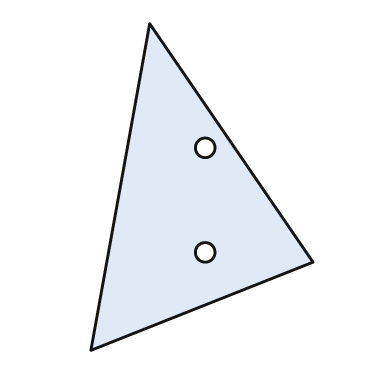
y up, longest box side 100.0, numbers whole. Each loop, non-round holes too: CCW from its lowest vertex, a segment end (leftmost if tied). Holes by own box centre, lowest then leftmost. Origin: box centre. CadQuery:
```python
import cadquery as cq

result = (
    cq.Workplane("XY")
    .moveTo(-34.0, -50.0)
    .lineTo(34.0, -23.0)
    .lineTo(-16.0, 50.0)
    .close()
    .moveTo(1.0, -20.0)
    .circle(3.0)
    .moveTo(1.0, 12.0)
    .circle(3.0)
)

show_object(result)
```